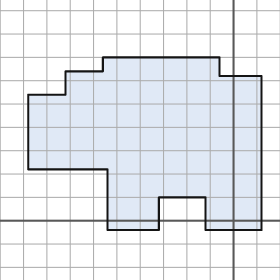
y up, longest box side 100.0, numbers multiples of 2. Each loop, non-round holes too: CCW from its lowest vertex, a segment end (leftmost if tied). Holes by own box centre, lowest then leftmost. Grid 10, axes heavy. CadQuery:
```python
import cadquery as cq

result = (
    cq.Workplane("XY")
    .moveTo(-54.0, -4.0)
    .lineTo(-32.0, -4.0)
    .lineTo(-32.0, 10.0)
    .lineTo(-12.0, 10.0)
    .lineTo(-12.0, -4.0)
    .lineTo(12.0, -4.0)
    .lineTo(12.0, 62.0)
    .lineTo(-6.0, 62.0)
    .lineTo(-6.0, 70.0)
    .lineTo(-56.0, 70.0)
    .lineTo(-56.0, 64.0)
    .lineTo(-72.0, 64.0)
    .lineTo(-72.0, 54.0)
    .lineTo(-88.0, 54.0)
    .lineTo(-88.0, 22.0)
    .lineTo(-54.0, 22.0)
    .close()
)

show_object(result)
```